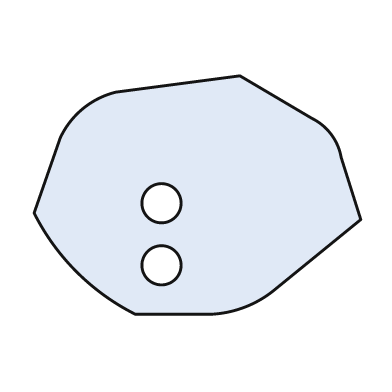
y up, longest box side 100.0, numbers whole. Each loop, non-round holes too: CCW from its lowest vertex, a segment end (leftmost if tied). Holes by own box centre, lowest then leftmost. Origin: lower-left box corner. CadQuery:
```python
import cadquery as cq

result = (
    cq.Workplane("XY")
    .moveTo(31.0, 0.0)
    .lineTo(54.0, 0.0)
    .threePointArc((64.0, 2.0), (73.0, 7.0))
    .lineTo(100.0, 29.0)
    .lineTo(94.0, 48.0)
    .threePointArc((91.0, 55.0), (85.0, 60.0))
    .lineTo(63.0, 73.0)
    .lineTo(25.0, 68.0)
    .threePointArc((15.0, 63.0), (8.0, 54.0))
    .lineTo(0.0, 31.0)
    .threePointArc((13.0, 13.0), (31.0, 0.0))
    .close()
    .moveTo(39.0, 15.0)
    .circle(6.0)
    .moveTo(39.0, 34.0)
    .circle(6.0)
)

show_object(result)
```